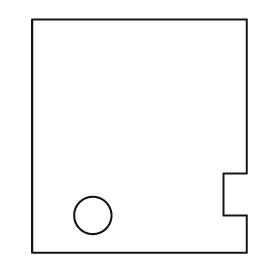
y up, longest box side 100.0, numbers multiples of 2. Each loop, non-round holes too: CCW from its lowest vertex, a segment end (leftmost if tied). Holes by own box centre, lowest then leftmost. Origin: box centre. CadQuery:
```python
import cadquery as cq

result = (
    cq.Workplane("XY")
    .moveTo(-46.0, -50.0)
    .lineTo(46.0, -50.0)
    .lineTo(46.0, -34.0)
    .lineTo(36.0, -34.0)
    .lineTo(36.0, -16.0)
    .lineTo(46.0, -16.0)
    .lineTo(46.0, 50.0)
    .lineTo(-46.0, 50.0)
    .close()
    .moveTo(-20.0, -34.0)
    .circle(8.0)
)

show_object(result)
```